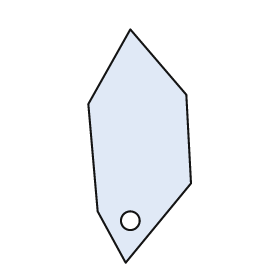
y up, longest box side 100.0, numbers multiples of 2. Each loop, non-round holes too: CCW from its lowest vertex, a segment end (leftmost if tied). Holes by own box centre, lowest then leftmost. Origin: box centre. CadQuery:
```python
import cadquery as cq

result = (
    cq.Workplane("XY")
    .moveTo(-6.0, -50.0)
    .lineTo(22.0, -16.0)
    .lineTo(20.0, 22.0)
    .lineTo(-4.0, 50.0)
    .lineTo(-22.0, 18.0)
    .lineTo(-18.0, -28.0)
    .close()
    .moveTo(-4.0, -32.0)
    .circle(4.0)
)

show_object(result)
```